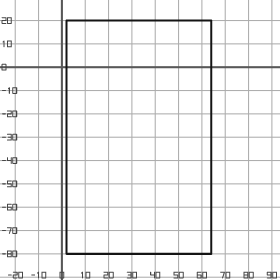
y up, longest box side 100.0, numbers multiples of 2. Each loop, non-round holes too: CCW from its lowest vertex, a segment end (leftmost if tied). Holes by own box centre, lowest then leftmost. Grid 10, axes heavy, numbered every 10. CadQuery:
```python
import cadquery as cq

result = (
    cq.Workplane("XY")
    .moveTo(2.0, -80.0)
    .lineTo(64.0, -80.0)
    .lineTo(64.0, 20.0)
    .lineTo(2.0, 20.0)
    .close()
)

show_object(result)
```